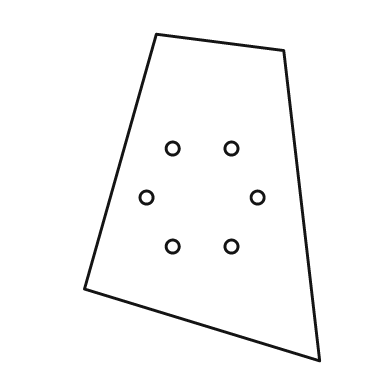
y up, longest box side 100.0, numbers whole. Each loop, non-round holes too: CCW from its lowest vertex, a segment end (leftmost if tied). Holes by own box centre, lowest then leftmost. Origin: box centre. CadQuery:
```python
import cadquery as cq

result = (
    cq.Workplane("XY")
    .moveTo(36.0, -50.0)
    .lineTo(25.0, 45.0)
    .lineTo(-14.0, 50.0)
    .lineTo(-36.0, -28.0)
    .close()
    .moveTo(-9.0, -15.0)
    .circle(2.0)
    .moveTo(9.0, -15.0)
    .circle(2.0)
    .moveTo(-17.0, 0.0)
    .circle(2.0)
    .moveTo(17.0, 0.0)
    .circle(2.0)
    .moveTo(-9.0, 15.0)
    .circle(2.0)
    .moveTo(9.0, 15.0)
    .circle(2.0)
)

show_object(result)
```